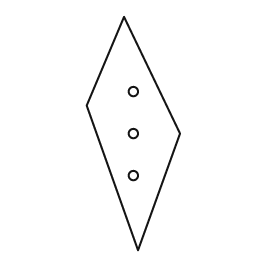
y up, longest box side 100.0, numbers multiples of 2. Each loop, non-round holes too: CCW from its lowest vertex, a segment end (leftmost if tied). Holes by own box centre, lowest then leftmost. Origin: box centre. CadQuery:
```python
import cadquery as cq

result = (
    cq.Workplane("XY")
    .moveTo(2.0, -50.0)
    .lineTo(20.0, 0.0)
    .lineTo(-4.0, 50.0)
    .lineTo(-20.0, 12.0)
    .close()
    .moveTo(0.0, -18.0)
    .circle(2.0)
    .moveTo(0.0, 0.0)
    .circle(2.0)
    .moveTo(0.0, 18.0)
    .circle(2.0)
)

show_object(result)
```